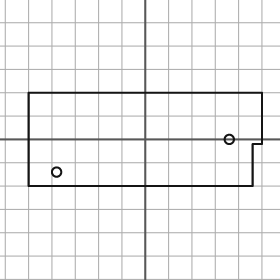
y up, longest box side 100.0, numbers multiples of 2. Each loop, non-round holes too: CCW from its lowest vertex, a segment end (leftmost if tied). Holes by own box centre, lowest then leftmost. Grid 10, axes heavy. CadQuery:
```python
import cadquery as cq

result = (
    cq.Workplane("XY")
    .moveTo(-50.0, -20.0)
    .lineTo(46.0, -20.0)
    .lineTo(46.0, -2.0)
    .lineTo(50.0, -2.0)
    .lineTo(50.0, 20.0)
    .lineTo(-50.0, 20.0)
    .close()
    .moveTo(-38.0, -14.0)
    .circle(2.0)
    .moveTo(36.0, 0.0)
    .circle(2.0)
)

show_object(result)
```